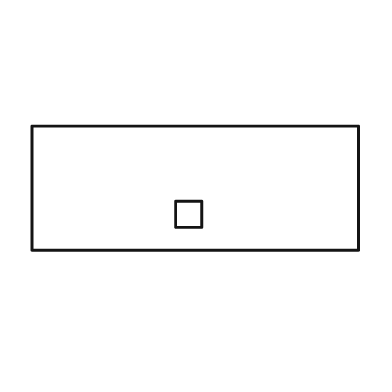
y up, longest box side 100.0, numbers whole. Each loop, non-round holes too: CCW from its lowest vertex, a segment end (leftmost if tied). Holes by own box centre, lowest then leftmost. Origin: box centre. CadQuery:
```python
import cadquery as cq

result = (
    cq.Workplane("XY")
    .moveTo(-50.0, -19.0)
    .lineTo(50.0, -19.0)
    .lineTo(50.0, 19.0)
    .lineTo(-50.0, 19.0)
    .close()
    .moveTo(-6.0, -12.0)
    .lineTo(2.0, -12.0)
    .lineTo(2.0, -4.0)
    .lineTo(-6.0, -4.0)
    .close()
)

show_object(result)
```